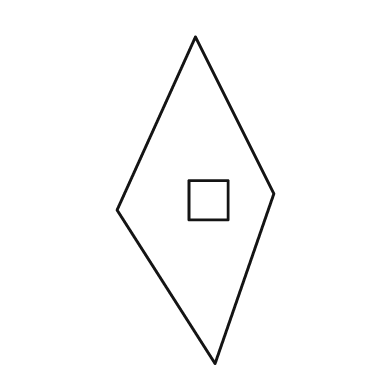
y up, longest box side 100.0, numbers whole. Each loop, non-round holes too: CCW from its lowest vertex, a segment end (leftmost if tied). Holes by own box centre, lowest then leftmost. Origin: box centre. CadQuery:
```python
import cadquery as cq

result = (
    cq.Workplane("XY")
    .moveTo(6.0, -50.0)
    .lineTo(24.0, 2.0)
    .lineTo(0.0, 50.0)
    .lineTo(-24.0, -3.0)
    .close()
    .moveTo(-2.0, -6.0)
    .lineTo(10.0, -6.0)
    .lineTo(10.0, 6.0)
    .lineTo(-2.0, 6.0)
    .close()
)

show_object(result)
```